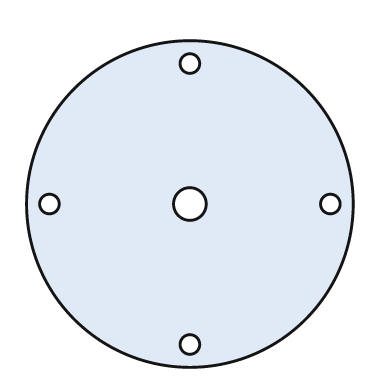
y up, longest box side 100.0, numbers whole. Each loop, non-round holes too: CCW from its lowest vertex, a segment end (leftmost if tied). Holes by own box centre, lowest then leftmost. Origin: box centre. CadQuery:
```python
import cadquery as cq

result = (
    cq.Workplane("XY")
    .moveTo(0.0, 0.0)
    .circle(50.0)
    .moveTo(0.0, -43.0)
    .circle(3.0)
    .moveTo(-43.0, 0.0)
    .circle(3.0)
    .moveTo(0.0, 0.0)
    .circle(5.0)
    .moveTo(43.0, 0.0)
    .circle(3.0)
    .moveTo(0.0, 43.0)
    .circle(3.0)
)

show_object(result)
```